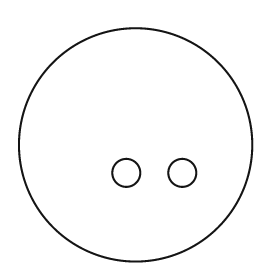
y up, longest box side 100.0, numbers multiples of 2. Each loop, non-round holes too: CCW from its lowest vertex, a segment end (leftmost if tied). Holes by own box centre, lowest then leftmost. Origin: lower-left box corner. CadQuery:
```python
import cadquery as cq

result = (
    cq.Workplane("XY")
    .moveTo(50.0, 50.0)
    .circle(50.0)
    .moveTo(46.0, 38.0)
    .circle(6.0)
    .moveTo(70.0, 38.0)
    .circle(6.0)
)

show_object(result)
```